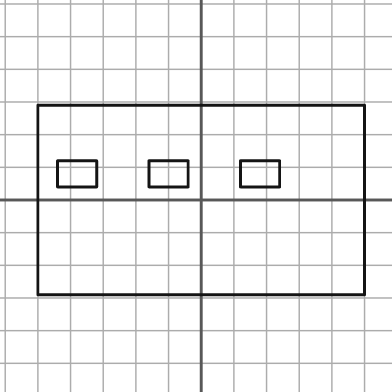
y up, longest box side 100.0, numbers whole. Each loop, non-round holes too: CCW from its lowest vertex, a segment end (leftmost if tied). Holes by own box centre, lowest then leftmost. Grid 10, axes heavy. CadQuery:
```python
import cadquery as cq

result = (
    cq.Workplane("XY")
    .moveTo(-50.0, -29.0)
    .lineTo(50.0, -29.0)
    .lineTo(50.0, 29.0)
    .lineTo(-50.0, 29.0)
    .close()
    .moveTo(-44.0, 4.0)
    .lineTo(-32.0, 4.0)
    .lineTo(-32.0, 12.0)
    .lineTo(-44.0, 12.0)
    .close()
    .moveTo(-16.0, 4.0)
    .lineTo(-4.0, 4.0)
    .lineTo(-4.0, 12.0)
    .lineTo(-16.0, 12.0)
    .close()
    .moveTo(12.0, 4.0)
    .lineTo(24.0, 4.0)
    .lineTo(24.0, 12.0)
    .lineTo(12.0, 12.0)
    .close()
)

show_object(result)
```